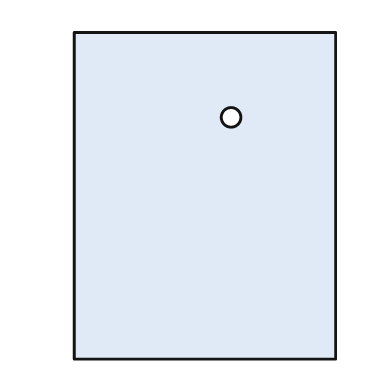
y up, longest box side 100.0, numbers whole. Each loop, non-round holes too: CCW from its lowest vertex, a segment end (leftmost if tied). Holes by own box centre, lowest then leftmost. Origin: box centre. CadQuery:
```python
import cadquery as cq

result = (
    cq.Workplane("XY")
    .moveTo(-40.0, -50.0)
    .lineTo(40.0, -50.0)
    .lineTo(40.0, 50.0)
    .lineTo(-40.0, 50.0)
    .close()
    .moveTo(8.0, 24.0)
    .circle(3.0)
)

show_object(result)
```